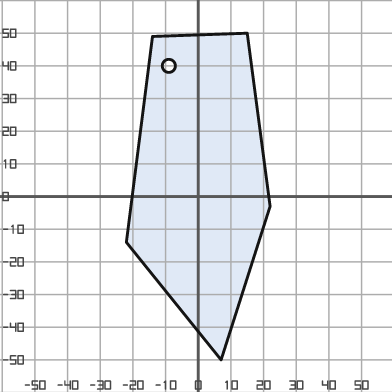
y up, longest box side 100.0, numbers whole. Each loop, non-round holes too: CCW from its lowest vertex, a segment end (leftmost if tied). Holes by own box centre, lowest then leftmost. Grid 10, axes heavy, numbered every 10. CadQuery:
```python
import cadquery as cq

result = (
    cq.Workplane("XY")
    .moveTo(7.0, -50.0)
    .lineTo(22.0, -3.0)
    .lineTo(15.0, 50.0)
    .lineTo(-14.0, 49.0)
    .lineTo(-22.0, -14.0)
    .close()
    .moveTo(-9.0, 40.0)
    .circle(2.0)
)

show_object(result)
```